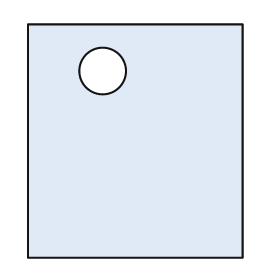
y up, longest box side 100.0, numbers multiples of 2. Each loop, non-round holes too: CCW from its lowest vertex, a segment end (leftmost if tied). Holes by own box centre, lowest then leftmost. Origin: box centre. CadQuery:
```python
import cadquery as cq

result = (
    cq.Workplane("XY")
    .moveTo(-46.0, -50.0)
    .lineTo(46.0, -50.0)
    .lineTo(46.0, 50.0)
    .lineTo(-46.0, 50.0)
    .close()
    .moveTo(-14.0, 30.0)
    .circle(10.0)
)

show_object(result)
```